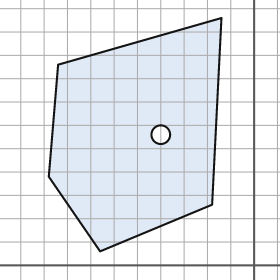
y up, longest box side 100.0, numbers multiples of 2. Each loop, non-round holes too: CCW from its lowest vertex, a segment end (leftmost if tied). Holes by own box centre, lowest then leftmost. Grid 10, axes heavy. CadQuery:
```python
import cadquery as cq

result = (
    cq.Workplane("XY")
    .moveTo(-66.0, 6.0)
    .lineTo(-18.0, 26.0)
    .lineTo(-14.0, 106.0)
    .lineTo(-84.0, 86.0)
    .lineTo(-88.0, 38.0)
    .close()
    .moveTo(-40.0, 56.0)
    .circle(4.0)
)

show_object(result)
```